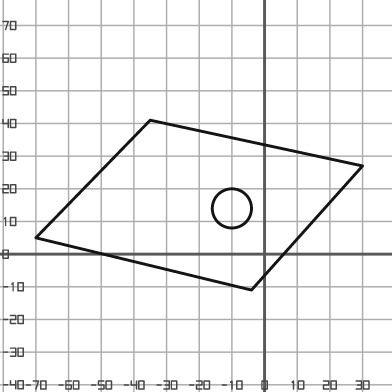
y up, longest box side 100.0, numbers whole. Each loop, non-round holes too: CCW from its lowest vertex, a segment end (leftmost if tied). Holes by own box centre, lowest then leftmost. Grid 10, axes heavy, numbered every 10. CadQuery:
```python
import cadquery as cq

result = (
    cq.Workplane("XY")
    .moveTo(-4.0, -11.0)
    .lineTo(30.0, 27.0)
    .lineTo(-35.0, 41.0)
    .lineTo(-70.0, 5.0)
    .close()
    .moveTo(-10.0, 14.0)
    .circle(6.0)
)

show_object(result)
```